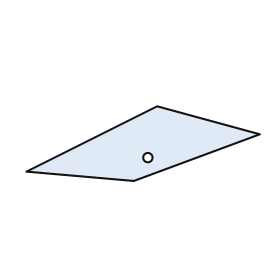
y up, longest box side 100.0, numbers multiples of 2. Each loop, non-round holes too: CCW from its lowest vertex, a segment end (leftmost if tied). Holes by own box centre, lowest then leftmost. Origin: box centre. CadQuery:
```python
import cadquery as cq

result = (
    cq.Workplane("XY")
    .moveTo(-4.0, -16.0)
    .lineTo(50.0, 4.0)
    .lineTo(6.0, 16.0)
    .lineTo(-50.0, -12.0)
    .close()
    .moveTo(2.0, -6.0)
    .circle(2.0)
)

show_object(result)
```